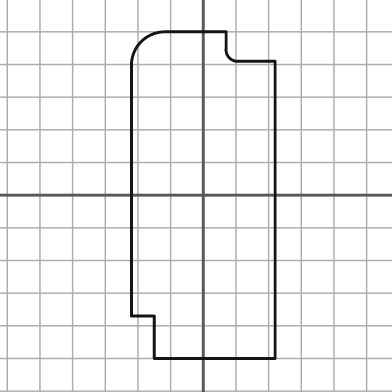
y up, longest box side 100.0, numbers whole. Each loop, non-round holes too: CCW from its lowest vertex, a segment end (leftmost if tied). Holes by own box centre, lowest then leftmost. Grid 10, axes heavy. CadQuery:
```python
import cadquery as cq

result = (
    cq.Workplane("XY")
    .moveTo(-15.0, -50.0)
    .lineTo(22.0, -50.0)
    .lineTo(22.0, 41.0)
    .lineTo(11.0, 41.0)
    .threePointArc((8.0, 42.0), (7.0, 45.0))
    .lineTo(7.0, 50.0)
    .lineTo(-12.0, 50.0)
    .threePointArc((-19.0, 47.0), (-22.0, 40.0))
    .lineTo(-22.0, -37.0)
    .lineTo(-15.0, -37.0)
    .close()
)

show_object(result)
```